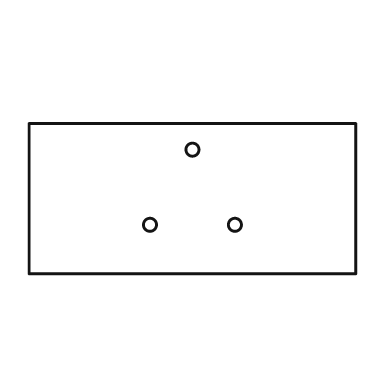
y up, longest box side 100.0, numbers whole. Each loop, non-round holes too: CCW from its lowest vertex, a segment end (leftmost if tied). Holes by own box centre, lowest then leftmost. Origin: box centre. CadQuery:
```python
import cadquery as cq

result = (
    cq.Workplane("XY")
    .moveTo(-50.0, -23.0)
    .lineTo(50.0, -23.0)
    .lineTo(50.0, 23.0)
    .lineTo(-50.0, 23.0)
    .close()
    .moveTo(-13.0, -8.0)
    .circle(2.0)
    .moveTo(13.0, -8.0)
    .circle(2.0)
    .moveTo(0.0, 15.0)
    .circle(2.0)
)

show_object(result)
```